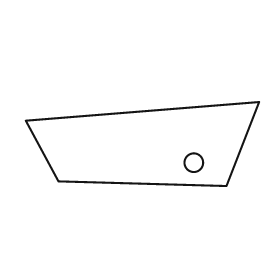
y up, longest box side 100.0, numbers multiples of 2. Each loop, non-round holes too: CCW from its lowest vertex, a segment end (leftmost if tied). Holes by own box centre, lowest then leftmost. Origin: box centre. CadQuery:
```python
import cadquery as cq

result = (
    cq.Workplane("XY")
    .moveTo(36.0, -18.0)
    .lineTo(50.0, 18.0)
    .lineTo(-50.0, 10.0)
    .lineTo(-36.0, -16.0)
    .close()
    .moveTo(22.0, -8.0)
    .circle(4.0)
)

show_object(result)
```